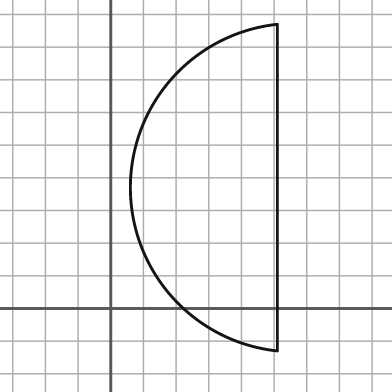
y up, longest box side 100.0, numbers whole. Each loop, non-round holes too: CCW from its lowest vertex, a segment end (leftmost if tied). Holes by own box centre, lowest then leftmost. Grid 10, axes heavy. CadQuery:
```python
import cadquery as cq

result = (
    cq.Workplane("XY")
    .moveTo(51.0, -13.0)
    .lineTo(51.0, 87.0)
    .threePointArc((6.0, 37.0), (51.0, -13.0))
    .close()
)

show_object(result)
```